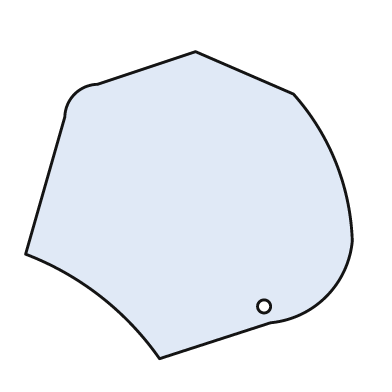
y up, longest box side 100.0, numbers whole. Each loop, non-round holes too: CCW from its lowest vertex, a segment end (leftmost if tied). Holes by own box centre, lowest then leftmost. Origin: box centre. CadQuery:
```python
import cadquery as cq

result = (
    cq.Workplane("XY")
    .moveTo(-9.0, -47.0)
    .lineTo(25.0, -36.0)
    .threePointArc((42.0, -28.0), (50.0, -11.0))
    .threePointArc((45.0, 13.0), (32.0, 34.0))
    .lineTo(2.0, 47.0)
    .lineTo(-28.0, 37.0)
    .threePointArc((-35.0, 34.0), (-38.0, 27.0))
    .lineTo(-50.0, -15.0)
    .threePointArc((-27.0, -28.0), (-9.0, -47.0))
    .close()
    .moveTo(23.0, -31.0)
    .circle(2.0)
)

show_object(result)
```